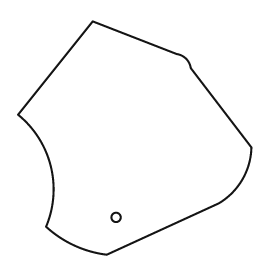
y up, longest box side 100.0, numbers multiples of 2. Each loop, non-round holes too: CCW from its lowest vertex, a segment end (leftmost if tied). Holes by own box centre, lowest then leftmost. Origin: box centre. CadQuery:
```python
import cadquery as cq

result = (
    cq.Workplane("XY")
    .moveTo(-12.0, -50.0)
    .lineTo(36.0, -28.0)
    .threePointArc((46.0, -18.0), (50.0, -4.0))
    .lineTo(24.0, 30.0)
    .threePointArc((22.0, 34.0), (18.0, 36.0))
    .lineTo(-18.0, 50.0)
    .lineTo(-50.0, 10.0)
    .threePointArc((-36.0, -12.0), (-38.0, -38.0))
    .threePointArc((-26.0, -46.0), (-12.0, -50.0))
    .close()
    .moveTo(-8.0, -34.0)
    .circle(2.0)
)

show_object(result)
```